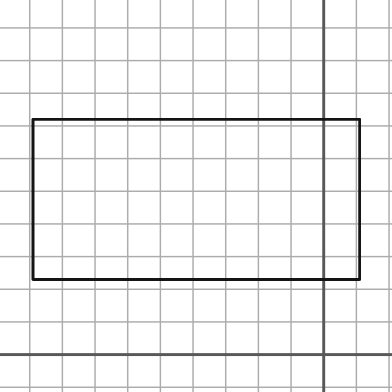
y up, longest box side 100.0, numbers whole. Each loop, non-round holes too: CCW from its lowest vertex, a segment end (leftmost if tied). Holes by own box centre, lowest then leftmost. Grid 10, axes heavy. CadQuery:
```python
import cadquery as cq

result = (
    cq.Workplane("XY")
    .moveTo(-89.0, 23.0)
    .lineTo(11.0, 23.0)
    .lineTo(11.0, 72.0)
    .lineTo(-89.0, 72.0)
    .close()
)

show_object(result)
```